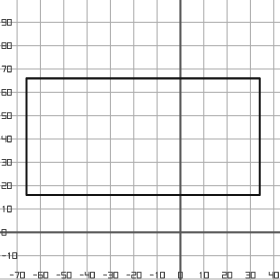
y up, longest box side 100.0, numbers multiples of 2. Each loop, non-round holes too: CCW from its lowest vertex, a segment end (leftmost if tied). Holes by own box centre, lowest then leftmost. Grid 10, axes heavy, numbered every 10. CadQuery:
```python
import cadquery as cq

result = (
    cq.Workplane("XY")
    .moveTo(-66.0, 16.0)
    .lineTo(34.0, 16.0)
    .lineTo(34.0, 66.0)
    .lineTo(-66.0, 66.0)
    .close()
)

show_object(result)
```